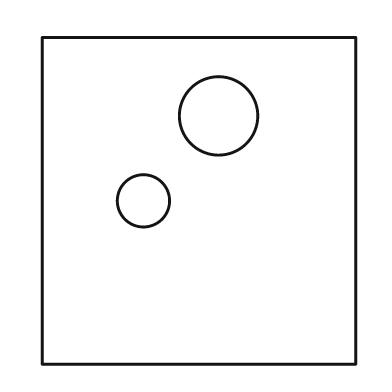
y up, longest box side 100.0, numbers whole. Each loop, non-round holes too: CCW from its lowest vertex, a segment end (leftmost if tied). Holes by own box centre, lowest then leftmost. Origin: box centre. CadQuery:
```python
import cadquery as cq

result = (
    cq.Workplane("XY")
    .moveTo(-48.0, -50.0)
    .lineTo(48.0, -50.0)
    .lineTo(48.0, 50.0)
    .lineTo(-48.0, 50.0)
    .close()
    .moveTo(-17.0, 0.0)
    .circle(8.0)
    .moveTo(6.0, 26.0)
    .circle(12.0)
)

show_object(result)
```